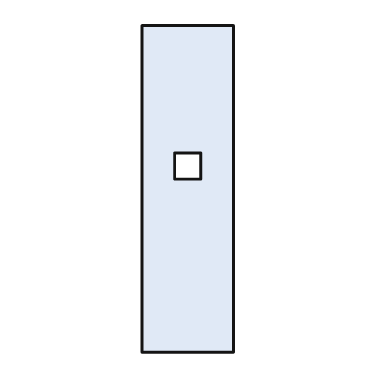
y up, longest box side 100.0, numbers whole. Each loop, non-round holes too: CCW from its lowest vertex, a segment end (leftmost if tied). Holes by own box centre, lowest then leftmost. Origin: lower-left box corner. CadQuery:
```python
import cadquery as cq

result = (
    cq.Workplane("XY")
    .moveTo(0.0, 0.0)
    .lineTo(28.0, 0.0)
    .lineTo(28.0, 100.0)
    .lineTo(0.0, 100.0)
    .close()
    .moveTo(10.0, 53.0)
    .lineTo(18.0, 53.0)
    .lineTo(18.0, 61.0)
    .lineTo(10.0, 61.0)
    .close()
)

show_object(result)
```